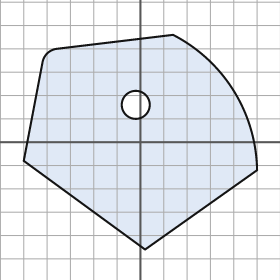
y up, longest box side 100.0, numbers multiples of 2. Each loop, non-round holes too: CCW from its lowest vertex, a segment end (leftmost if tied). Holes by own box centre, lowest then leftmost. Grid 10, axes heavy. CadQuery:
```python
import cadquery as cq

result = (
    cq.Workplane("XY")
    .moveTo(2.0, -46.0)
    .lineTo(50.0, -12.0)
    .threePointArc((40.0, 22.0), (14.0, 46.0))
    .lineTo(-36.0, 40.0)
    .threePointArc((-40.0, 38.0), (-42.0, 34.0))
    .lineTo(-50.0, -8.0)
    .close()
    .moveTo(-2.0, 16.0)
    .circle(6.0)
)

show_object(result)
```